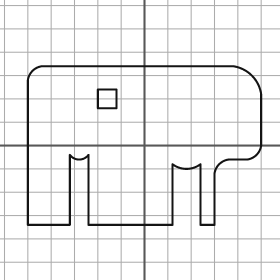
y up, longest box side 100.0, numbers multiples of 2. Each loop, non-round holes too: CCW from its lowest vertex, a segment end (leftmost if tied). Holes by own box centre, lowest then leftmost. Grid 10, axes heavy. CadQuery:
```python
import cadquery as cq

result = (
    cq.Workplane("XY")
    .moveTo(-50.0, -34.0)
    .lineTo(-32.0, -34.0)
    .lineTo(-32.0, -4.0)
    .threePointArc((-28.0, -6.0), (-24.0, -4.0))
    .lineTo(-24.0, -34.0)
    .lineTo(12.0, -34.0)
    .lineTo(12.0, -8.0)
    .threePointArc((18.0, -10.0), (24.0, -8.0))
    .lineTo(24.0, -34.0)
    .lineTo(30.0, -34.0)
    .lineTo(30.0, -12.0)
    .threePointArc((32.0, -8.0), (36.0, -6.0))
    .lineTo(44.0, -6.0)
    .threePointArc((48.0, -4.0), (50.0, 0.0))
    .lineTo(50.0, 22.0)
    .threePointArc((46.0, 30.0), (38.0, 34.0))
    .lineTo(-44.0, 34.0)
    .threePointArc((-48.0, 32.0), (-50.0, 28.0))
    .close()
    .moveTo(-20.0, 16.0)
    .lineTo(-12.0, 16.0)
    .lineTo(-12.0, 24.0)
    .lineTo(-20.0, 24.0)
    .close()
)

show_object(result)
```